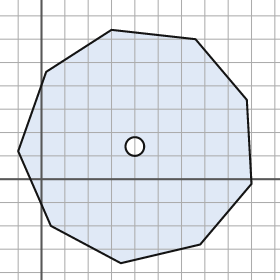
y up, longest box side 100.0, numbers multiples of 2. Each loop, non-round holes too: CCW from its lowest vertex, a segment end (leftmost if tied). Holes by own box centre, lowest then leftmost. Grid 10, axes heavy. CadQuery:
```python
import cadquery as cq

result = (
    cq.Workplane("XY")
    .moveTo(34.0, -36.0)
    .lineTo(68.0, -28.0)
    .lineTo(90.0, -2.0)
    .lineTo(88.0, 34.0)
    .lineTo(66.0, 60.0)
    .lineTo(30.0, 64.0)
    .lineTo(2.0, 46.0)
    .lineTo(-10.0, 12.0)
    .lineTo(4.0, -20.0)
    .close()
    .moveTo(40.0, 14.0)
    .circle(4.0)
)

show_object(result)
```